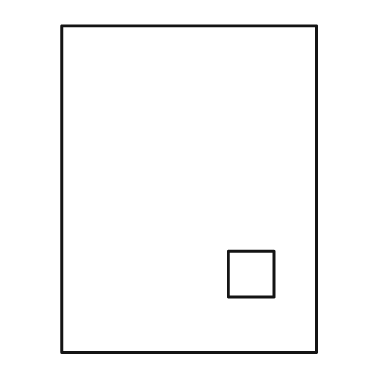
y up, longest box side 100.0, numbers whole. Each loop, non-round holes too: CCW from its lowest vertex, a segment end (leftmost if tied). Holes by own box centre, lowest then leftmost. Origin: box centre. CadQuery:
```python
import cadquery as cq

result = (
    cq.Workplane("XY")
    .moveTo(-39.0, -50.0)
    .lineTo(39.0, -50.0)
    .lineTo(39.0, 50.0)
    .lineTo(-39.0, 50.0)
    .close()
    .moveTo(12.0, -33.0)
    .lineTo(26.0, -33.0)
    .lineTo(26.0, -19.0)
    .lineTo(12.0, -19.0)
    .close()
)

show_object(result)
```